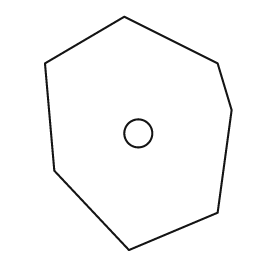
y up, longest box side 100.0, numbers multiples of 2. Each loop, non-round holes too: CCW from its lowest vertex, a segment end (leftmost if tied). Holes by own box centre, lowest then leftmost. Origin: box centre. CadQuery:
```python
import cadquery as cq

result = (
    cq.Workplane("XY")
    .moveTo(-4.0, -50.0)
    .lineTo(34.0, -34.0)
    .lineTo(40.0, 10.0)
    .lineTo(34.0, 30.0)
    .lineTo(-6.0, 50.0)
    .lineTo(-40.0, 30.0)
    .lineTo(-36.0, -16.0)
    .close()
    .moveTo(0.0, 0.0)
    .circle(6.0)
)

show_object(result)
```